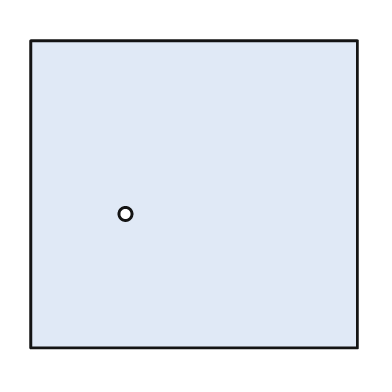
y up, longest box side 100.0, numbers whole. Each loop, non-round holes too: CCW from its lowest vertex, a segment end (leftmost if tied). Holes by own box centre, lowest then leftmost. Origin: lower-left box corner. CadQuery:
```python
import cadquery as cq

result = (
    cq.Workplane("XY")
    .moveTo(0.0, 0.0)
    .lineTo(100.0, 0.0)
    .lineTo(100.0, 94.0)
    .lineTo(0.0, 94.0)
    .close()
    .moveTo(29.0, 41.0)
    .circle(2.0)
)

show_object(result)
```